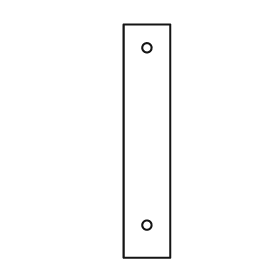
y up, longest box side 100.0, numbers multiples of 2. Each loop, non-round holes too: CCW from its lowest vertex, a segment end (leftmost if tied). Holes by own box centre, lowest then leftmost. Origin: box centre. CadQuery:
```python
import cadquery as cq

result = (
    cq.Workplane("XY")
    .moveTo(-10.0, -50.0)
    .lineTo(10.0, -50.0)
    .lineTo(10.0, 50.0)
    .lineTo(-10.0, 50.0)
    .close()
    .moveTo(0.0, -36.0)
    .circle(2.0)
    .moveTo(0.0, 40.0)
    .circle(2.0)
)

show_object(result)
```